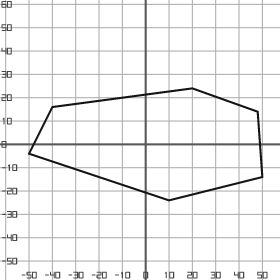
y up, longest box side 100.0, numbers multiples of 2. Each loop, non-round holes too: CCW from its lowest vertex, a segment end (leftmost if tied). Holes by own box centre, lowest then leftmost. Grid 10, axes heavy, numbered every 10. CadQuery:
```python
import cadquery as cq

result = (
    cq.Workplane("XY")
    .moveTo(10.0, -24.0)
    .lineTo(50.0, -14.0)
    .lineTo(48.0, 14.0)
    .lineTo(20.0, 24.0)
    .lineTo(-40.0, 16.0)
    .lineTo(-50.0, -4.0)
    .close()
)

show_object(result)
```